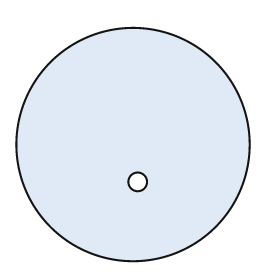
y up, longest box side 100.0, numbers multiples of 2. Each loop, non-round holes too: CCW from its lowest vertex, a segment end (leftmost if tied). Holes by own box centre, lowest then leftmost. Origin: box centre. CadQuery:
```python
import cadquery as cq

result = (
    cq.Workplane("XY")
    .moveTo(0.0, 0.0)
    .circle(50.0)
    .moveTo(2.0, -16.0)
    .circle(4.0)
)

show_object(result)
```